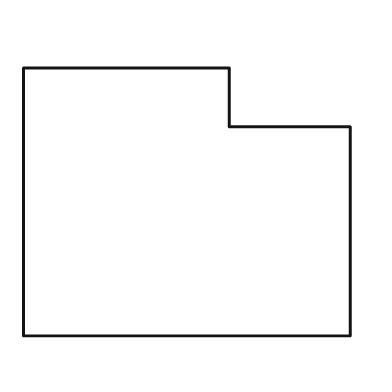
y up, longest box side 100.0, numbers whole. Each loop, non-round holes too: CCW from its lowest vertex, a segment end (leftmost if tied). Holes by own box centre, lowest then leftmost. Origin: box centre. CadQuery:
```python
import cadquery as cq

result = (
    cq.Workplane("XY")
    .moveTo(-50.0, -41.0)
    .lineTo(50.0, -41.0)
    .lineTo(50.0, 23.0)
    .lineTo(13.0, 23.0)
    .lineTo(13.0, 41.0)
    .lineTo(-50.0, 41.0)
    .close()
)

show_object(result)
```